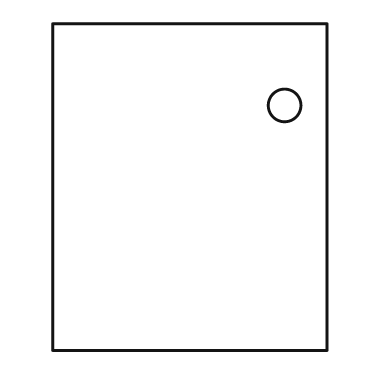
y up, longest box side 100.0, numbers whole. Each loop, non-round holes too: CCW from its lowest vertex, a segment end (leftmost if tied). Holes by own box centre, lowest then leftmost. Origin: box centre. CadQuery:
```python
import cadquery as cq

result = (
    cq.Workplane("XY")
    .moveTo(-42.0, -50.0)
    .lineTo(42.0, -50.0)
    .lineTo(42.0, 50.0)
    .lineTo(-42.0, 50.0)
    .close()
    .moveTo(29.0, 25.0)
    .circle(5.0)
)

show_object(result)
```